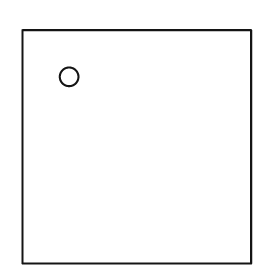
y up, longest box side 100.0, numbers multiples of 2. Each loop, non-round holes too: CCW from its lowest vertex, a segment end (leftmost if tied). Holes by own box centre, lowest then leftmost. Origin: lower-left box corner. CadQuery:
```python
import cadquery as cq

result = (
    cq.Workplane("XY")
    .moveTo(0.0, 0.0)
    .lineTo(98.0, 0.0)
    .lineTo(98.0, 100.0)
    .lineTo(0.0, 100.0)
    .close()
    .moveTo(20.0, 80.0)
    .circle(4.0)
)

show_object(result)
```